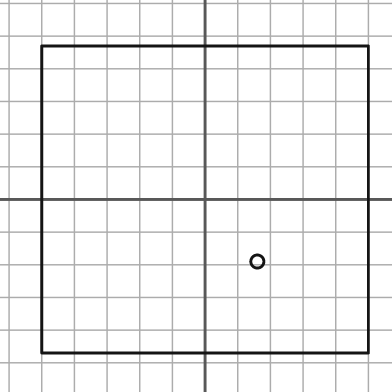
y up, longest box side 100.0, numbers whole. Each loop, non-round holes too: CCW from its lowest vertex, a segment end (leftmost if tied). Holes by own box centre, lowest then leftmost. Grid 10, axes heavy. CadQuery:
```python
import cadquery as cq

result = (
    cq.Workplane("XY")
    .moveTo(-50.0, -47.0)
    .lineTo(50.0, -47.0)
    .lineTo(50.0, 47.0)
    .lineTo(-50.0, 47.0)
    .close()
    .moveTo(16.0, -19.0)
    .circle(2.0)
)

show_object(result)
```